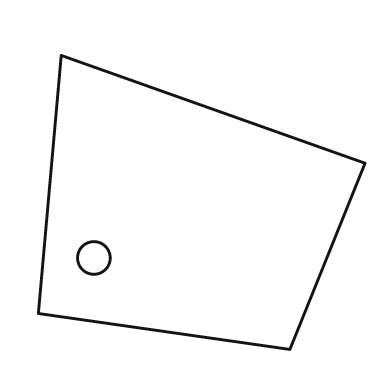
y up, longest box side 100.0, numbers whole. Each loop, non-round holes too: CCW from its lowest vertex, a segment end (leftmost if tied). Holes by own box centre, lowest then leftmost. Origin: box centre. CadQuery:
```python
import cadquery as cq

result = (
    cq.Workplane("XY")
    .moveTo(27.0, -45.0)
    .lineTo(50.0, 12.0)
    .lineTo(-43.0, 45.0)
    .lineTo(-50.0, -34.0)
    .close()
    .moveTo(-33.0, -17.0)
    .circle(5.0)
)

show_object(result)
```